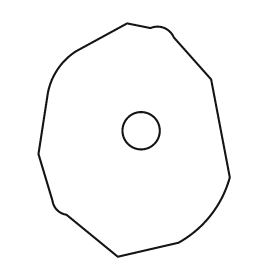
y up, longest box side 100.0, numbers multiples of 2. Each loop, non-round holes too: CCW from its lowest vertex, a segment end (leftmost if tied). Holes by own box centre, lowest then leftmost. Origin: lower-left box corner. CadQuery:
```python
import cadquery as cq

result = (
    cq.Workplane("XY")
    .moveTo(34.0, 0.0)
    .lineTo(60.0, 6.0)
    .threePointArc((74.0, 18.0), (82.0, 34.0))
    .lineTo(74.0, 76.0)
    .lineTo(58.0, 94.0)
    .threePointArc((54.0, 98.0), (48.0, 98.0))
    .lineTo(38.0, 100.0)
    .lineTo(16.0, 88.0)
    .threePointArc((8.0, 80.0), (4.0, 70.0))
    .lineTo(0.0, 44.0)
    .lineTo(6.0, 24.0)
    .threePointArc((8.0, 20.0), (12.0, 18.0))
    .close()
    .moveTo(44.0, 54.0)
    .circle(8.0)
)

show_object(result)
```